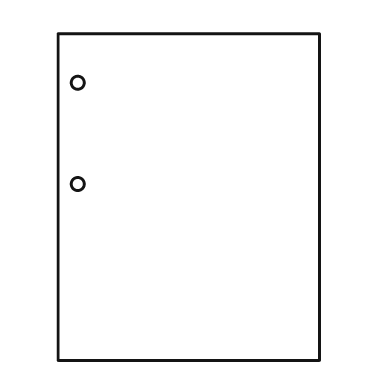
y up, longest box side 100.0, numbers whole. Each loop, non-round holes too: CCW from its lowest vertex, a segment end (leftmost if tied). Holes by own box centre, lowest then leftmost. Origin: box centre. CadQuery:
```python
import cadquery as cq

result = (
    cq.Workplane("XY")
    .moveTo(-40.0, -50.0)
    .lineTo(40.0, -50.0)
    .lineTo(40.0, 50.0)
    .lineTo(-40.0, 50.0)
    .close()
    .moveTo(-34.0, 4.0)
    .circle(2.0)
    .moveTo(-34.0, 35.0)
    .circle(2.0)
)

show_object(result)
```